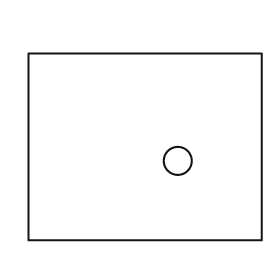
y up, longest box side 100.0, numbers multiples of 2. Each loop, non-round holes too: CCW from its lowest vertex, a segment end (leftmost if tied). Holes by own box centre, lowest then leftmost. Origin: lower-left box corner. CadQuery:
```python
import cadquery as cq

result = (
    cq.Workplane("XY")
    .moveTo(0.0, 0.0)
    .lineTo(100.0, 0.0)
    .lineTo(100.0, 80.0)
    .lineTo(0.0, 80.0)
    .close()
    .moveTo(64.0, 34.0)
    .circle(6.0)
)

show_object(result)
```